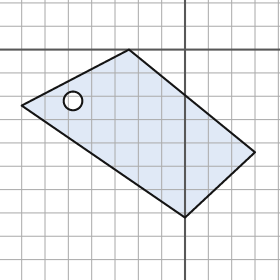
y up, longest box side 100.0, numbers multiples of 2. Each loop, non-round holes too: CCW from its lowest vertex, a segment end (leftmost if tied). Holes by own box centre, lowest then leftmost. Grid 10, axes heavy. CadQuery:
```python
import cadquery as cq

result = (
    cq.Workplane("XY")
    .moveTo(0.0, -72.0)
    .lineTo(30.0, -44.0)
    .lineTo(-24.0, 0.0)
    .lineTo(-70.0, -24.0)
    .close()
    .moveTo(-48.0, -22.0)
    .circle(4.0)
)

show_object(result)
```